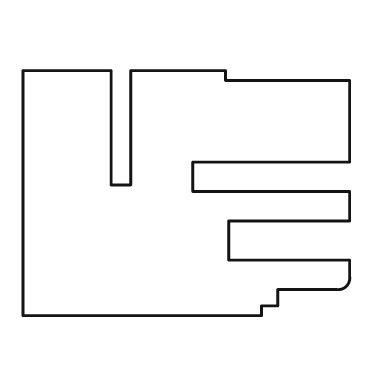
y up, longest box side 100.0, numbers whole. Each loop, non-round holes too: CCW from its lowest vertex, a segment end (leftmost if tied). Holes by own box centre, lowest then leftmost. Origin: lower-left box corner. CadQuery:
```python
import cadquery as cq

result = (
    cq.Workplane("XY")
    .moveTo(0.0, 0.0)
    .lineTo(73.0, 0.0)
    .lineTo(73.0, 3.0)
    .lineTo(78.0, 3.0)
    .lineTo(78.0, 8.0)
    .lineTo(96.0, 8.0)
    .threePointArc((99.0, 9.0), (100.0, 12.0))
    .lineTo(100.0, 17.0)
    .lineTo(63.0, 17.0)
    .lineTo(63.0, 29.0)
    .lineTo(100.0, 29.0)
    .lineTo(100.0, 38.0)
    .lineTo(52.0, 38.0)
    .lineTo(52.0, 47.0)
    .lineTo(100.0, 47.0)
    .lineTo(100.0, 72.0)
    .lineTo(62.0, 72.0)
    .lineTo(62.0, 75.0)
    .lineTo(33.0, 75.0)
    .lineTo(33.0, 40.0)
    .lineTo(27.0, 40.0)
    .lineTo(27.0, 75.0)
    .lineTo(0.0, 75.0)
    .close()
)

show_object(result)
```